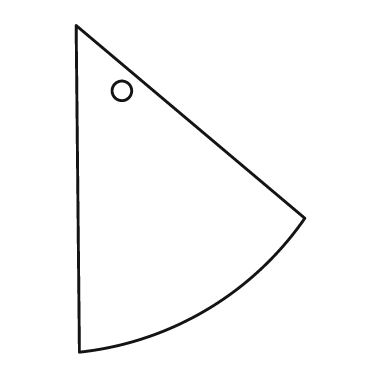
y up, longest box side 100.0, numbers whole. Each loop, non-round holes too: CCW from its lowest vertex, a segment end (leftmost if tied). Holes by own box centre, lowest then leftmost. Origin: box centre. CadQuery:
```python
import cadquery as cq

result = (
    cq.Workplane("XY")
    .moveTo(-34.0, -50.0)
    .threePointArc((5.0, -37.0), (35.0, -9.0))
    .lineTo(-35.0, 50.0)
    .close()
    .moveTo(-21.0, 30.0)
    .circle(3.0)
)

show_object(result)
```